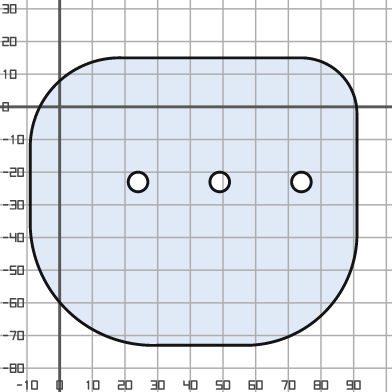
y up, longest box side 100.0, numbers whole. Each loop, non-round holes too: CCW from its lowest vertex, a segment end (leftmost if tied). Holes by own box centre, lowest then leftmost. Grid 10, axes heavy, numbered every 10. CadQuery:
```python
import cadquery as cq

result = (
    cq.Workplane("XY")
    .moveTo(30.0, -73.0)
    .lineTo(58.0, -73.0)
    .threePointArc((81.0, -63.0), (91.0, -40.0))
    .lineTo(91.0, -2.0)
    .threePointArc((86.0, 10.0), (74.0, 15.0))
    .lineTo(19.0, 15.0)
    .threePointArc((-1.0, 7.0), (-9.0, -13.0))
    .lineTo(-9.0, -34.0)
    .threePointArc((2.0, -62.0), (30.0, -73.0))
    .close()
    .moveTo(24.0, -23.0)
    .circle(3.0)
    .moveTo(49.0, -23.0)
    .circle(3.0)
    .moveTo(74.0, -23.0)
    .circle(3.0)
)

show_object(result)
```